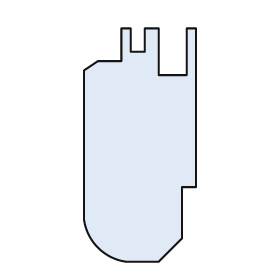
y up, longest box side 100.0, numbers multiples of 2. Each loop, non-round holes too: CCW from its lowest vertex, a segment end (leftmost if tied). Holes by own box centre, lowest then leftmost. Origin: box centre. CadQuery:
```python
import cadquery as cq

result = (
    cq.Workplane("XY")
    .moveTo(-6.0, -50.0)
    .lineTo(8.0, -50.0)
    .lineTo(18.0, -40.0)
    .lineTo(18.0, -18.0)
    .lineTo(24.0, -18.0)
    .lineTo(24.0, 50.0)
    .lineTo(20.0, 50.0)
    .lineTo(20.0, 30.0)
    .lineTo(8.0, 30.0)
    .lineTo(8.0, 50.0)
    .lineTo(2.0, 50.0)
    .lineTo(2.0, 40.0)
    .lineTo(-4.0, 40.0)
    .lineTo(-4.0, 50.0)
    .lineTo(-8.0, 50.0)
    .lineTo(-8.0, 36.0)
    .lineTo(-18.0, 36.0)
    .lineTo(-24.0, 32.0)
    .lineTo(-24.0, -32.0)
    .threePointArc((-18.0, -44.0), (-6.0, -50.0))
    .close()
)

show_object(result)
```